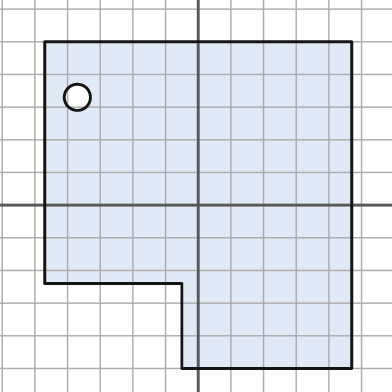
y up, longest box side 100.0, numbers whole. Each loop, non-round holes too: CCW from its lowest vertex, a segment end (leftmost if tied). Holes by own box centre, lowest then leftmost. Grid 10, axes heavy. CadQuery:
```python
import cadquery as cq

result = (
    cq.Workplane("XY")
    .moveTo(-5.0, -50.0)
    .lineTo(47.0, -50.0)
    .lineTo(47.0, 50.0)
    .lineTo(-47.0, 50.0)
    .lineTo(-47.0, -24.0)
    .lineTo(-5.0, -24.0)
    .close()
    .moveTo(-37.0, 33.0)
    .circle(4.0)
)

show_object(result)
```